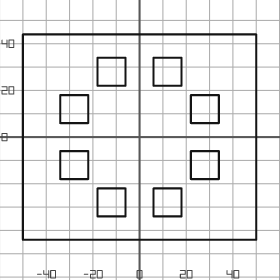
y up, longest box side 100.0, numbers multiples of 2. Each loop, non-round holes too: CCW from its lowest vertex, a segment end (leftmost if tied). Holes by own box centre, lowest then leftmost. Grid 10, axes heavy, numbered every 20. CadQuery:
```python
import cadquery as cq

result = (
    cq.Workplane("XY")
    .moveTo(-50.0, -44.0)
    .lineTo(50.0, -44.0)
    .lineTo(50.0, 44.0)
    .lineTo(-50.0, 44.0)
    .close()
    .moveTo(-18.0, -34.0)
    .lineTo(-6.0, -34.0)
    .lineTo(-6.0, -22.0)
    .lineTo(-18.0, -22.0)
    .close()
    .moveTo(6.0, -34.0)
    .lineTo(18.0, -34.0)
    .lineTo(18.0, -22.0)
    .lineTo(6.0, -22.0)
    .close()
    .moveTo(-34.0, -18.0)
    .lineTo(-22.0, -18.0)
    .lineTo(-22.0, -6.0)
    .lineTo(-34.0, -6.0)
    .close()
    .moveTo(22.0, -18.0)
    .lineTo(34.0, -18.0)
    .lineTo(34.0, -6.0)
    .lineTo(22.0, -6.0)
    .close()
    .moveTo(-34.0, 6.0)
    .lineTo(-22.0, 6.0)
    .lineTo(-22.0, 18.0)
    .lineTo(-34.0, 18.0)
    .close()
    .moveTo(22.0, 6.0)
    .lineTo(34.0, 6.0)
    .lineTo(34.0, 18.0)
    .lineTo(22.0, 18.0)
    .close()
    .moveTo(-18.0, 22.0)
    .lineTo(-6.0, 22.0)
    .lineTo(-6.0, 34.0)
    .lineTo(-18.0, 34.0)
    .close()
    .moveTo(6.0, 22.0)
    .lineTo(18.0, 22.0)
    .lineTo(18.0, 34.0)
    .lineTo(6.0, 34.0)
    .close()
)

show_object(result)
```